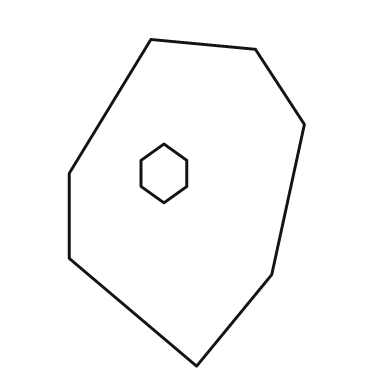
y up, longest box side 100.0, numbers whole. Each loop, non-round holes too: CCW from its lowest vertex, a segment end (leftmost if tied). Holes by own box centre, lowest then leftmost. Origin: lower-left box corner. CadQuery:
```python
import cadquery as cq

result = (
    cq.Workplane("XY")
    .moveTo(39.0, 0.0)
    .lineTo(62.0, 28.0)
    .lineTo(72.0, 74.0)
    .lineTo(57.0, 97.0)
    .lineTo(25.0, 100.0)
    .lineTo(0.0, 59.0)
    .lineTo(0.0, 33.0)
    .close()
    .moveTo(29.0, 50.0)
    .lineTo(36.0, 55.0)
    .lineTo(36.0, 63.0)
    .lineTo(29.0, 68.0)
    .lineTo(22.0, 63.0)
    .lineTo(22.0, 55.0)
    .close()
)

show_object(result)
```